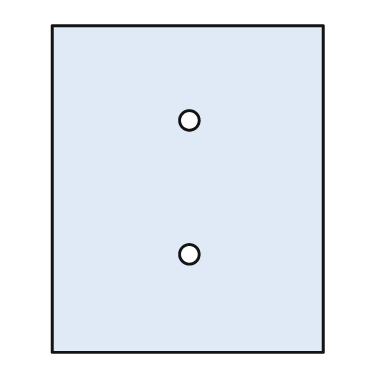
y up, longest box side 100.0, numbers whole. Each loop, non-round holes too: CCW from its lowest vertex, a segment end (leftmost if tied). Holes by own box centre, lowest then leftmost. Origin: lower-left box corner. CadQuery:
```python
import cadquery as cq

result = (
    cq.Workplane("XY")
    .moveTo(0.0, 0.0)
    .lineTo(83.0, 0.0)
    .lineTo(83.0, 100.0)
    .lineTo(0.0, 100.0)
    .close()
    .moveTo(42.0, 30.0)
    .circle(3.0)
    .moveTo(42.0, 71.0)
    .circle(3.0)
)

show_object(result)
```